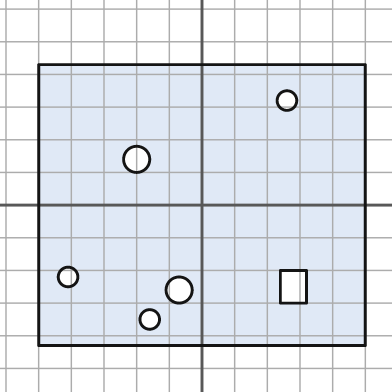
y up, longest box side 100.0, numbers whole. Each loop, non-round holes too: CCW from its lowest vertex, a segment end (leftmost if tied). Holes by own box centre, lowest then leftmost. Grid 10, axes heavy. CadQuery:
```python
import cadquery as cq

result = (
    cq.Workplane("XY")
    .moveTo(-50.0, -43.0)
    .lineTo(50.0, -43.0)
    .lineTo(50.0, 43.0)
    .lineTo(-50.0, 43.0)
    .close()
    .moveTo(-16.0, -35.0)
    .circle(3.0)
    .moveTo(-7.0, -26.0)
    .circle(4.0)
    .moveTo(24.0, -30.0)
    .lineTo(32.0, -30.0)
    .lineTo(32.0, -20.0)
    .lineTo(24.0, -20.0)
    .close()
    .moveTo(-41.0, -22.0)
    .circle(3.0)
    .moveTo(-20.0, 14.0)
    .circle(4.0)
    .moveTo(26.0, 32.0)
    .circle(3.0)
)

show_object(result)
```